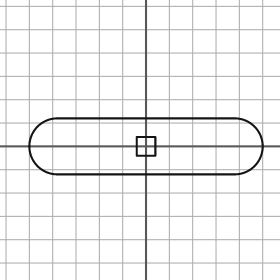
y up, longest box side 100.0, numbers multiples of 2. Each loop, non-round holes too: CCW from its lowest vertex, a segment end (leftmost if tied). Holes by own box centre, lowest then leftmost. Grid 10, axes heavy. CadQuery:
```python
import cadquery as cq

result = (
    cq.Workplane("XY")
    .moveTo(-38.0, -12.0)
    .lineTo(38.0, -12.0)
    .threePointArc((50.0, 0.0), (38.0, 12.0))
    .lineTo(-38.0, 12.0)
    .threePointArc((-50.0, 0.0), (-38.0, -12.0))
    .close()
    .moveTo(-4.0, -4.0)
    .lineTo(4.0, -4.0)
    .lineTo(4.0, 4.0)
    .lineTo(-4.0, 4.0)
    .close()
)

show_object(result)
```